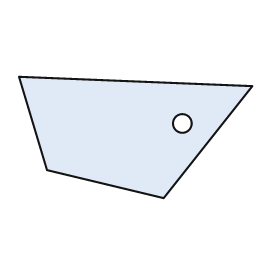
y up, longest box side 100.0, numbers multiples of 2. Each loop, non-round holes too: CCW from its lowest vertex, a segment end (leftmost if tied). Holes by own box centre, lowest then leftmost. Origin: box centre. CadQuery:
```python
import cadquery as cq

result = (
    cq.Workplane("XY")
    .moveTo(12.0, -26.0)
    .lineTo(50.0, 22.0)
    .lineTo(-50.0, 26.0)
    .lineTo(-38.0, -14.0)
    .close()
    .moveTo(20.0, 6.0)
    .circle(4.0)
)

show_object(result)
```